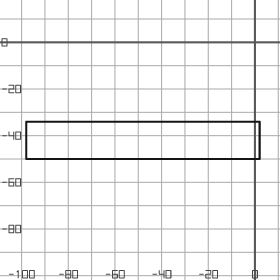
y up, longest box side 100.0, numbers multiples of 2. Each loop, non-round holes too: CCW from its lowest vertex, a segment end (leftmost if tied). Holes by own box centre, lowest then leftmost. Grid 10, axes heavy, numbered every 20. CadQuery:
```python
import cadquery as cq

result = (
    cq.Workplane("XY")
    .moveTo(-98.0, -50.0)
    .lineTo(2.0, -50.0)
    .lineTo(2.0, -34.0)
    .lineTo(-98.0, -34.0)
    .close()
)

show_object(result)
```